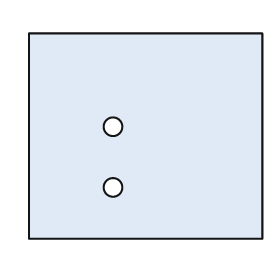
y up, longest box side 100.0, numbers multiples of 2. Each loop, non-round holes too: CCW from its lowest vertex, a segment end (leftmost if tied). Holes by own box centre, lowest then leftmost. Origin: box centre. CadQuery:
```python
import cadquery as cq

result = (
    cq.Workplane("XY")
    .moveTo(-50.0, -44.0)
    .lineTo(50.0, -44.0)
    .lineTo(50.0, 44.0)
    .lineTo(-50.0, 44.0)
    .close()
    .moveTo(-14.0, -22.0)
    .circle(4.0)
    .moveTo(-14.0, 4.0)
    .circle(4.0)
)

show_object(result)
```